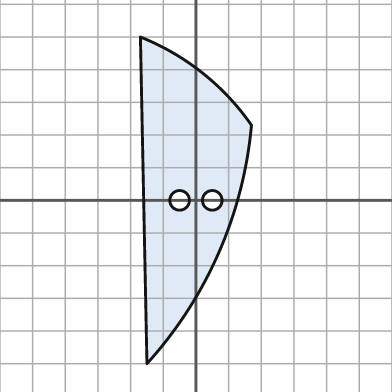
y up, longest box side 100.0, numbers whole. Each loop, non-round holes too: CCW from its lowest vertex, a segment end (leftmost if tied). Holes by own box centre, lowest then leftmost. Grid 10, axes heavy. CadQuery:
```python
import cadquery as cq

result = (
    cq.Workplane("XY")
    .moveTo(-15.0, -50.0)
    .threePointArc((7.0, -16.0), (17.0, 23.0))
    .threePointArc((2.0, 39.0), (-17.0, 50.0))
    .close()
    .moveTo(-5.0, 0.0)
    .circle(3.0)
    .moveTo(5.0, 0.0)
    .circle(3.0)
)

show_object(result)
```